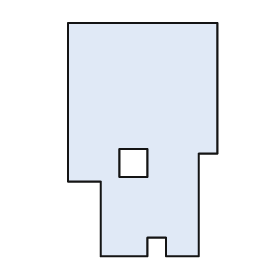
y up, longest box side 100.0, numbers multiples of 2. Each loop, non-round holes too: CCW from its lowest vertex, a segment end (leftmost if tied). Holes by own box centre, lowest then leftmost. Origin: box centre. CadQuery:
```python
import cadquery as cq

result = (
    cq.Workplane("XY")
    .moveTo(-18.0, -50.0)
    .lineTo(2.0, -50.0)
    .lineTo(2.0, -42.0)
    .lineTo(10.0, -42.0)
    .lineTo(10.0, -50.0)
    .lineTo(24.0, -50.0)
    .lineTo(24.0, -6.0)
    .lineTo(32.0, -6.0)
    .lineTo(32.0, 50.0)
    .lineTo(-32.0, 50.0)
    .lineTo(-32.0, -18.0)
    .lineTo(-18.0, -18.0)
    .close()
    .moveTo(-10.0, -16.0)
    .lineTo(2.0, -16.0)
    .lineTo(2.0, -4.0)
    .lineTo(-10.0, -4.0)
    .close()
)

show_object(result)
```